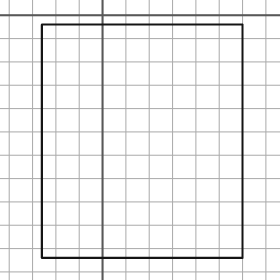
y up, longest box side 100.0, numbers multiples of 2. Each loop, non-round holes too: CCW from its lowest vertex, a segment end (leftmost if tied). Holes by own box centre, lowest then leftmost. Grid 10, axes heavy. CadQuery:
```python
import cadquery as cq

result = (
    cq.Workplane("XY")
    .moveTo(-26.0, -104.0)
    .lineTo(60.0, -104.0)
    .lineTo(60.0, -4.0)
    .lineTo(-26.0, -4.0)
    .close()
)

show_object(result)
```